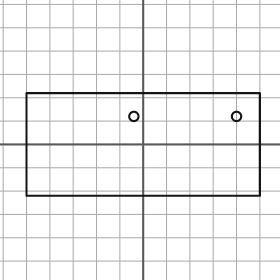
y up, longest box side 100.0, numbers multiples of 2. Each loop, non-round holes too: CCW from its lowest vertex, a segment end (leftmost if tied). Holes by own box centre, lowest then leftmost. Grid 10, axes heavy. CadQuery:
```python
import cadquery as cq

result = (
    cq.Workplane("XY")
    .moveTo(-50.0, -22.0)
    .lineTo(50.0, -22.0)
    .lineTo(50.0, 22.0)
    .lineTo(-50.0, 22.0)
    .close()
    .moveTo(-4.0, 12.0)
    .circle(2.0)
    .moveTo(40.0, 12.0)
    .circle(2.0)
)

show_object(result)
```